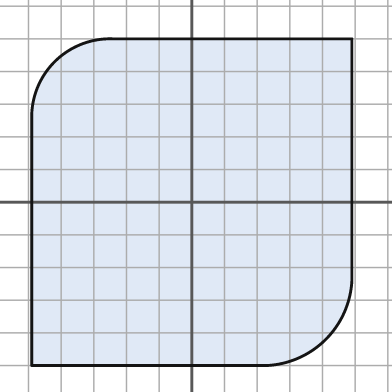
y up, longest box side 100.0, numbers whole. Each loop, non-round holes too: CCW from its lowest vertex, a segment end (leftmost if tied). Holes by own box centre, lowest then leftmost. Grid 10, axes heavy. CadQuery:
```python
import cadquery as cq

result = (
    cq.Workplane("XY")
    .moveTo(-49.0, -50.0)
    .lineTo(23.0, -50.0)
    .threePointArc((41.0, -42.0), (49.0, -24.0))
    .lineTo(49.0, 50.0)
    .lineTo(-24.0, 50.0)
    .threePointArc((-42.0, 43.0), (-49.0, 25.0))
    .close()
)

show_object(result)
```